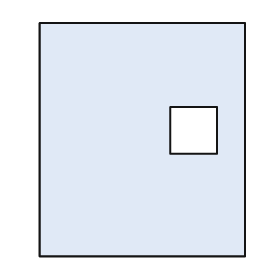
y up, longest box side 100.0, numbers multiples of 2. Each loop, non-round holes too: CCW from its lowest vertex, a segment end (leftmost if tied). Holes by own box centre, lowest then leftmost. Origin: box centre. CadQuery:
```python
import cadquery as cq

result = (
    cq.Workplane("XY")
    .moveTo(-44.0, -50.0)
    .lineTo(44.0, -50.0)
    .lineTo(44.0, 50.0)
    .lineTo(-44.0, 50.0)
    .close()
    .moveTo(12.0, -6.0)
    .lineTo(32.0, -6.0)
    .lineTo(32.0, 14.0)
    .lineTo(12.0, 14.0)
    .close()
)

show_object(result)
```